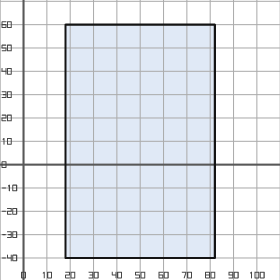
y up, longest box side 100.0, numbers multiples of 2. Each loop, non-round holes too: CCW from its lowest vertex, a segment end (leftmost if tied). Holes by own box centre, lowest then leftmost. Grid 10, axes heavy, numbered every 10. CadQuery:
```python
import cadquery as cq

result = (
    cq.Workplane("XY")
    .moveTo(18.0, -40.0)
    .lineTo(82.0, -40.0)
    .lineTo(82.0, 60.0)
    .lineTo(18.0, 60.0)
    .close()
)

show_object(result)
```